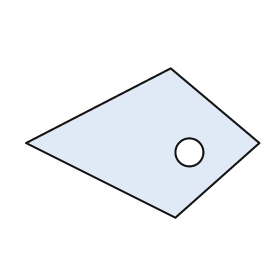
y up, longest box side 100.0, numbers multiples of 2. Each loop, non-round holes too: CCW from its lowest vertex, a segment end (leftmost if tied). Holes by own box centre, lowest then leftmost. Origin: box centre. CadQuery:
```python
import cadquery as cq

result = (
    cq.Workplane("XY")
    .moveTo(14.0, -32.0)
    .lineTo(50.0, 0.0)
    .lineTo(12.0, 32.0)
    .lineTo(-50.0, 0.0)
    .close()
    .moveTo(20.0, -4.0)
    .circle(6.0)
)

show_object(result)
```